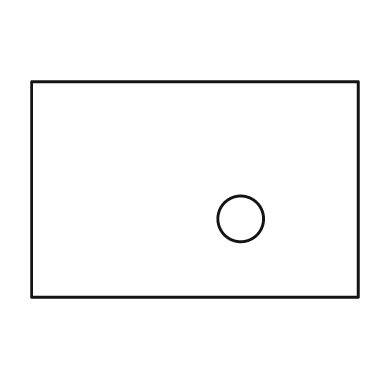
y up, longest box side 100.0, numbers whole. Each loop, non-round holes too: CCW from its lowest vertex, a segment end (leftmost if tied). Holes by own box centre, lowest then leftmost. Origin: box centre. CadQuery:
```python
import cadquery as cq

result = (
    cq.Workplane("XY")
    .moveTo(-50.0, -33.0)
    .lineTo(50.0, -33.0)
    .lineTo(50.0, 33.0)
    .lineTo(-50.0, 33.0)
    .close()
    .moveTo(14.0, -9.0)
    .circle(7.0)
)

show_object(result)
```